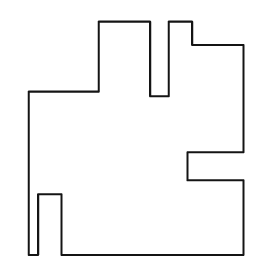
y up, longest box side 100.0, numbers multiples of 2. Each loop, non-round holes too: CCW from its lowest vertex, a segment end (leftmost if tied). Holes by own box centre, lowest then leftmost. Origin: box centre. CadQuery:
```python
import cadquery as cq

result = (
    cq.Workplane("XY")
    .moveTo(-46.0, -50.0)
    .lineTo(-42.0, -50.0)
    .lineTo(-42.0, -24.0)
    .lineTo(-32.0, -24.0)
    .lineTo(-32.0, -50.0)
    .lineTo(46.0, -50.0)
    .lineTo(46.0, -18.0)
    .lineTo(22.0, -18.0)
    .lineTo(22.0, -6.0)
    .lineTo(46.0, -6.0)
    .lineTo(46.0, 40.0)
    .lineTo(24.0, 40.0)
    .lineTo(24.0, 50.0)
    .lineTo(14.0, 50.0)
    .lineTo(14.0, 18.0)
    .lineTo(6.0, 18.0)
    .lineTo(6.0, 50.0)
    .lineTo(-16.0, 50.0)
    .lineTo(-16.0, 20.0)
    .lineTo(-46.0, 20.0)
    .close()
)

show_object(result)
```